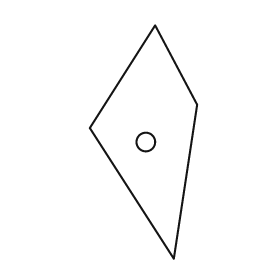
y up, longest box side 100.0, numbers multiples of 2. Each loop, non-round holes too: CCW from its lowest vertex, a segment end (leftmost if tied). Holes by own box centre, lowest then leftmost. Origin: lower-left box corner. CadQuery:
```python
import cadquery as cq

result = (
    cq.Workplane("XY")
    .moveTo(36.0, 0.0)
    .lineTo(46.0, 66.0)
    .lineTo(28.0, 100.0)
    .lineTo(0.0, 56.0)
    .close()
    .moveTo(24.0, 50.0)
    .circle(4.0)
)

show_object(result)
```